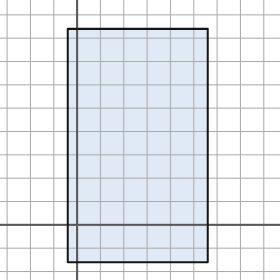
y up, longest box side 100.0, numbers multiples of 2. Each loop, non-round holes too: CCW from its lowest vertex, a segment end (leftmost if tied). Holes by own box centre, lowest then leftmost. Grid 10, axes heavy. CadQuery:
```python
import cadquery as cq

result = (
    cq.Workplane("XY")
    .moveTo(-4.0, -16.0)
    .lineTo(56.0, -16.0)
    .lineTo(56.0, 84.0)
    .lineTo(-4.0, 84.0)
    .close()
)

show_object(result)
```